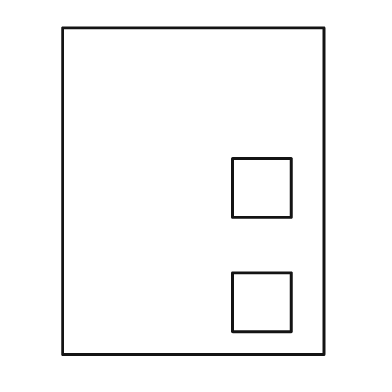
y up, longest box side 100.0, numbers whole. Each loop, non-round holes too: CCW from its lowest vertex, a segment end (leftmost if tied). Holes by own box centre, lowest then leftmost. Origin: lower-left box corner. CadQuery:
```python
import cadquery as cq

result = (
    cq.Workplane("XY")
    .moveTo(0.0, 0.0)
    .lineTo(80.0, 0.0)
    .lineTo(80.0, 100.0)
    .lineTo(0.0, 100.0)
    .close()
    .moveTo(52.0, 7.0)
    .lineTo(70.0, 7.0)
    .lineTo(70.0, 25.0)
    .lineTo(52.0, 25.0)
    .close()
    .moveTo(52.0, 42.0)
    .lineTo(70.0, 42.0)
    .lineTo(70.0, 60.0)
    .lineTo(52.0, 60.0)
    .close()
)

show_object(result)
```